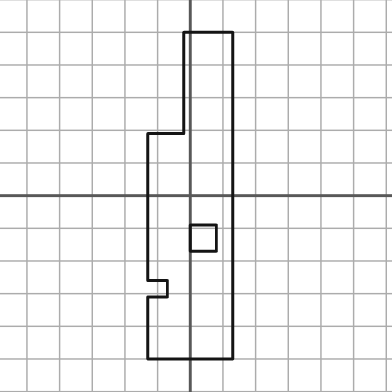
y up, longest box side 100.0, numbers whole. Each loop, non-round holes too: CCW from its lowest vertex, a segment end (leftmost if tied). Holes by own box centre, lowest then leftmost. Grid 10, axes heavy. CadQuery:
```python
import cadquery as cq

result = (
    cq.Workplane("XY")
    .moveTo(-13.0, -50.0)
    .lineTo(13.0, -50.0)
    .lineTo(13.0, 50.0)
    .lineTo(-2.0, 50.0)
    .lineTo(-2.0, 19.0)
    .lineTo(-13.0, 19.0)
    .lineTo(-13.0, -26.0)
    .lineTo(-7.0, -26.0)
    .lineTo(-7.0, -31.0)
    .lineTo(-13.0, -31.0)
    .close()
    .moveTo(0.0, -17.0)
    .lineTo(8.0, -17.0)
    .lineTo(8.0, -9.0)
    .lineTo(0.0, -9.0)
    .close()
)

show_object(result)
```